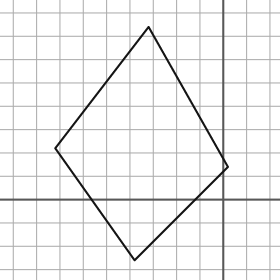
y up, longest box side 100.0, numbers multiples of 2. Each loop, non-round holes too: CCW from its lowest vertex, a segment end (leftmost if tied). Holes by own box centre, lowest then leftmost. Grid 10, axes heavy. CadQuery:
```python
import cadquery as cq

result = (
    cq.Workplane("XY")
    .moveTo(-38.0, -26.0)
    .lineTo(2.0, 14.0)
    .lineTo(-32.0, 74.0)
    .lineTo(-72.0, 22.0)
    .close()
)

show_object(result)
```